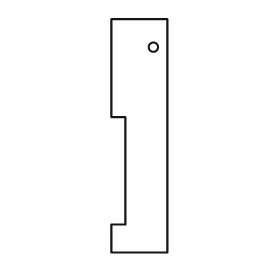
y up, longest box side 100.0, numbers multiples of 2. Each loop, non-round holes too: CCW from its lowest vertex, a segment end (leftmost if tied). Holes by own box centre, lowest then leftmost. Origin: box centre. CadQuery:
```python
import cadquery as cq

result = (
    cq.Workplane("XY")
    .moveTo(-12.0, -50.0)
    .lineTo(12.0, -50.0)
    .lineTo(12.0, 50.0)
    .lineTo(-12.0, 50.0)
    .lineTo(-12.0, 8.0)
    .lineTo(-6.0, 8.0)
    .lineTo(-6.0, -38.0)
    .lineTo(-12.0, -38.0)
    .close()
    .moveTo(6.0, 38.0)
    .circle(2.0)
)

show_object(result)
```